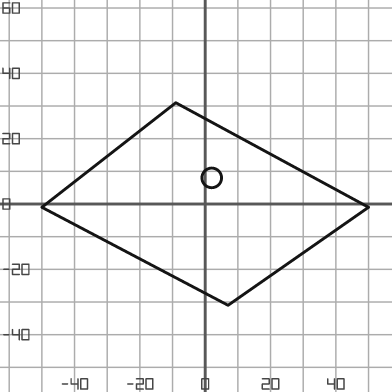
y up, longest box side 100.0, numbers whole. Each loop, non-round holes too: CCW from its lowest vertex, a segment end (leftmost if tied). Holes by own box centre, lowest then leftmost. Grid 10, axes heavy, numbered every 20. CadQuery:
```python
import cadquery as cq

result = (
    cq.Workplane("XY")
    .moveTo(7.0, -31.0)
    .lineTo(50.0, -1.0)
    .lineTo(-9.0, 31.0)
    .lineTo(-50.0, -1.0)
    .close()
    .moveTo(2.0, 8.0)
    .circle(3.0)
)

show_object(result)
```